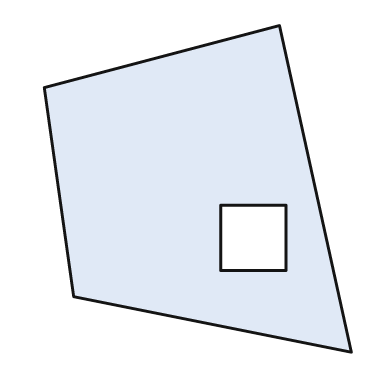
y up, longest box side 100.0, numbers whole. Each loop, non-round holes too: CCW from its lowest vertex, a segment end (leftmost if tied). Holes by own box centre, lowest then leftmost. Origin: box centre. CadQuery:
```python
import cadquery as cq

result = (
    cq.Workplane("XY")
    .moveTo(47.0, -50.0)
    .lineTo(25.0, 50.0)
    .lineTo(-47.0, 31.0)
    .lineTo(-38.0, -33.0)
    .close()
    .moveTo(7.0, -25.0)
    .lineTo(27.0, -25.0)
    .lineTo(27.0, -5.0)
    .lineTo(7.0, -5.0)
    .close()
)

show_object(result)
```